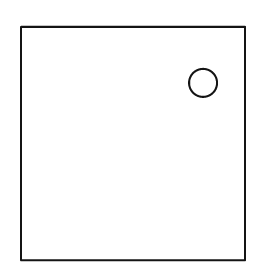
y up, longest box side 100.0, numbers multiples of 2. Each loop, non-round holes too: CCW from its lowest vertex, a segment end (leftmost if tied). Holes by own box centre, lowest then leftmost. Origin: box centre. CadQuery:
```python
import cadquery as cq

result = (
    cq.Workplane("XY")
    .moveTo(-48.0, -50.0)
    .lineTo(48.0, -50.0)
    .lineTo(48.0, 50.0)
    .lineTo(-48.0, 50.0)
    .close()
    .moveTo(30.0, 26.0)
    .circle(6.0)
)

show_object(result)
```